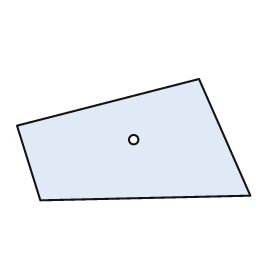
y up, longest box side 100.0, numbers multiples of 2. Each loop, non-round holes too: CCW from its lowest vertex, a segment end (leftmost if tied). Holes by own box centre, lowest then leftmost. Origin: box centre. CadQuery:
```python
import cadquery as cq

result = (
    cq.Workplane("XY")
    .moveTo(-40.0, -26.0)
    .lineTo(50.0, -24.0)
    .lineTo(28.0, 26.0)
    .lineTo(-50.0, 6.0)
    .close()
    .moveTo(0.0, 0.0)
    .circle(2.0)
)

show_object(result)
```